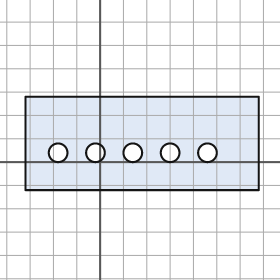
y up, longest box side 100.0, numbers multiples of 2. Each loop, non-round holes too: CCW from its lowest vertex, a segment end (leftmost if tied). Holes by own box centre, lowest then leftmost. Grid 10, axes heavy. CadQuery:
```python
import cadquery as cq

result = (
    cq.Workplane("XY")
    .moveTo(-32.0, -12.0)
    .lineTo(68.0, -12.0)
    .lineTo(68.0, 28.0)
    .lineTo(-32.0, 28.0)
    .close()
    .moveTo(-18.0, 4.0)
    .circle(4.0)
    .moveTo(-2.0, 4.0)
    .circle(4.0)
    .moveTo(14.0, 4.0)
    .circle(4.0)
    .moveTo(30.0, 4.0)
    .circle(4.0)
    .moveTo(46.0, 4.0)
    .circle(4.0)
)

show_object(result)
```